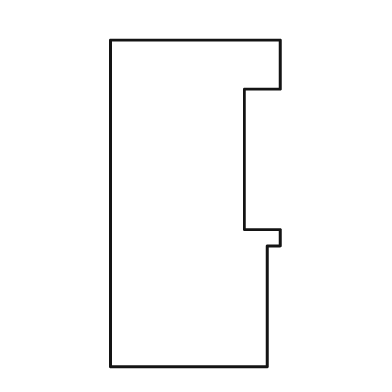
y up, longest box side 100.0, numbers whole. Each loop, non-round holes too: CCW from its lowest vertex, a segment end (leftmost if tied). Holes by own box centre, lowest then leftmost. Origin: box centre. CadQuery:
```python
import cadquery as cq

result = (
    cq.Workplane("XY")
    .moveTo(-26.0, -50.0)
    .lineTo(22.0, -50.0)
    .lineTo(22.0, -13.0)
    .lineTo(26.0, -13.0)
    .lineTo(26.0, -8.0)
    .lineTo(15.0, -8.0)
    .lineTo(15.0, 35.0)
    .lineTo(26.0, 35.0)
    .lineTo(26.0, 50.0)
    .lineTo(-26.0, 50.0)
    .close()
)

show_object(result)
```